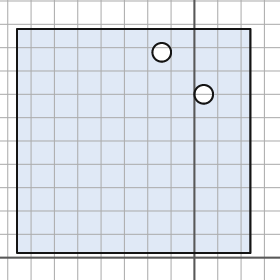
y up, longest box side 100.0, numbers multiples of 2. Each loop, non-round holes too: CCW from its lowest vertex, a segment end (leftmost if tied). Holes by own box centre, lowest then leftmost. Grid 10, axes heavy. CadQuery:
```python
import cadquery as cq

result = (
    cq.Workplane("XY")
    .moveTo(-76.0, 2.0)
    .lineTo(24.0, 2.0)
    .lineTo(24.0, 98.0)
    .lineTo(-76.0, 98.0)
    .close()
    .moveTo(4.0, 70.0)
    .circle(4.0)
    .moveTo(-14.0, 88.0)
    .circle(4.0)
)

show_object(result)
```